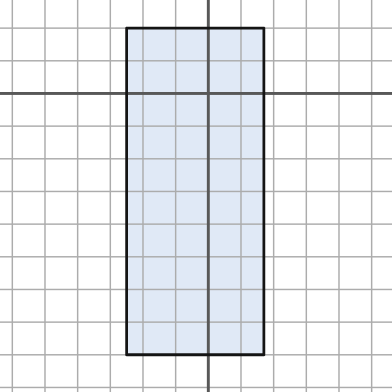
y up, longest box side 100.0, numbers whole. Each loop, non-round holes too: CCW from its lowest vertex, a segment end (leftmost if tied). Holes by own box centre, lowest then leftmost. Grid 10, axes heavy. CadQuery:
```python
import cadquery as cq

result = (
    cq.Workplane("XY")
    .moveTo(-25.0, -80.0)
    .lineTo(17.0, -80.0)
    .lineTo(17.0, 20.0)
    .lineTo(-25.0, 20.0)
    .close()
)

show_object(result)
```